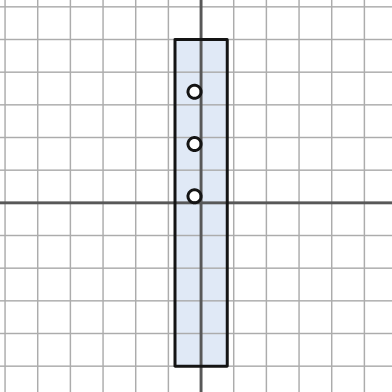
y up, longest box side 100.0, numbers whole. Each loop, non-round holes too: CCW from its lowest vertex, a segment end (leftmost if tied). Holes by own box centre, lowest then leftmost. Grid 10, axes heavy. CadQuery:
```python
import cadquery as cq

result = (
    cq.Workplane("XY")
    .moveTo(-8.0, -50.0)
    .lineTo(8.0, -50.0)
    .lineTo(8.0, 50.0)
    .lineTo(-8.0, 50.0)
    .close()
    .moveTo(-2.0, 2.0)
    .circle(2.0)
    .moveTo(-2.0, 18.0)
    .circle(2.0)
    .moveTo(-2.0, 34.0)
    .circle(2.0)
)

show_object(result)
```